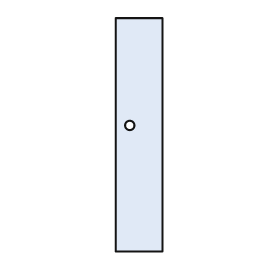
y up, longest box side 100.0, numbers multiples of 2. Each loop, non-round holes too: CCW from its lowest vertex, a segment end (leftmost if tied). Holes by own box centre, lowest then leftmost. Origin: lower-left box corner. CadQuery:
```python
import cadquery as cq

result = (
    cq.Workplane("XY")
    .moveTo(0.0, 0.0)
    .lineTo(20.0, 0.0)
    .lineTo(20.0, 100.0)
    .lineTo(0.0, 100.0)
    .close()
    .moveTo(6.0, 54.0)
    .circle(2.0)
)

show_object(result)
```